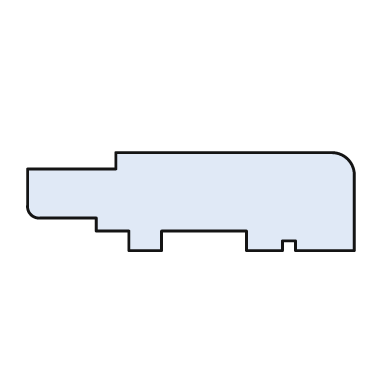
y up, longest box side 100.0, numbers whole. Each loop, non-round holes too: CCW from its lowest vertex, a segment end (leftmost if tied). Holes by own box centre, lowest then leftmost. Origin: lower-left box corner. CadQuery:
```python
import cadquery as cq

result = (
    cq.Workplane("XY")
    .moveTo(31.0, 0.0)
    .lineTo(41.0, 0.0)
    .lineTo(41.0, 6.0)
    .lineTo(67.0, 6.0)
    .lineTo(67.0, 0.0)
    .lineTo(78.0, 0.0)
    .lineTo(78.0, 3.0)
    .lineTo(82.0, 3.0)
    .lineTo(82.0, 0.0)
    .lineTo(100.0, 0.0)
    .lineTo(100.0, 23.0)
    .threePointArc((98.0, 28.0), (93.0, 30.0))
    .lineTo(27.0, 30.0)
    .lineTo(27.0, 25.0)
    .lineTo(0.0, 25.0)
    .lineTo(0.0, 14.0)
    .threePointArc((1.0, 11.0), (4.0, 10.0))
    .lineTo(21.0, 10.0)
    .lineTo(21.0, 6.0)
    .lineTo(31.0, 6.0)
    .close()
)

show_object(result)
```